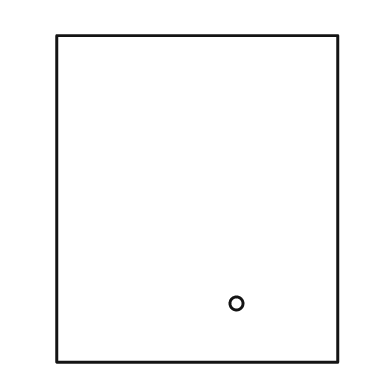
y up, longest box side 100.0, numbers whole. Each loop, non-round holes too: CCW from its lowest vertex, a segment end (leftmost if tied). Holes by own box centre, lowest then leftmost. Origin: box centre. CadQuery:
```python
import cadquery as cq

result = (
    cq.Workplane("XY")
    .moveTo(-43.0, -50.0)
    .lineTo(43.0, -50.0)
    .lineTo(43.0, 50.0)
    .lineTo(-43.0, 50.0)
    .close()
    .moveTo(12.0, -32.0)
    .circle(2.0)
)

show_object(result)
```